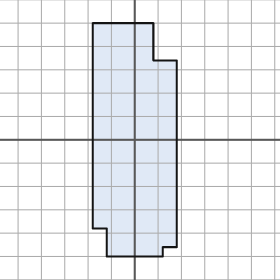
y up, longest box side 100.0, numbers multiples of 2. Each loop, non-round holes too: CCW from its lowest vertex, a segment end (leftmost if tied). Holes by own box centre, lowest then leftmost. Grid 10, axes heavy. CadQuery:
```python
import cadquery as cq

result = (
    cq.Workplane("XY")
    .moveTo(-12.0, -50.0)
    .lineTo(12.0, -50.0)
    .lineTo(12.0, -46.0)
    .lineTo(18.0, -46.0)
    .lineTo(18.0, 34.0)
    .lineTo(8.0, 34.0)
    .lineTo(8.0, 50.0)
    .lineTo(-18.0, 50.0)
    .lineTo(-18.0, -38.0)
    .lineTo(-12.0, -38.0)
    .close()
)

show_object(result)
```